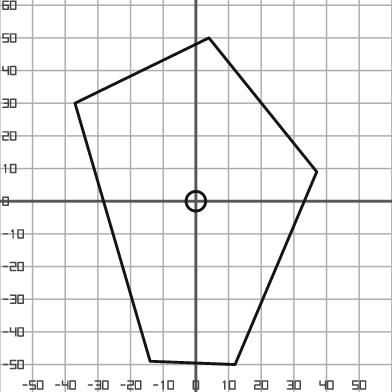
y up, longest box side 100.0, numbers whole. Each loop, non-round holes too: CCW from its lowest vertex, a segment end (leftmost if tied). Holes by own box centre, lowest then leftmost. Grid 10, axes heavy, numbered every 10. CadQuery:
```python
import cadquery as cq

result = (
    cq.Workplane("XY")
    .moveTo(12.0, -50.0)
    .lineTo(37.0, 9.0)
    .lineTo(4.0, 50.0)
    .lineTo(-37.0, 30.0)
    .lineTo(-14.0, -49.0)
    .close()
    .moveTo(0.0, 0.0)
    .circle(3.0)
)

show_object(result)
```